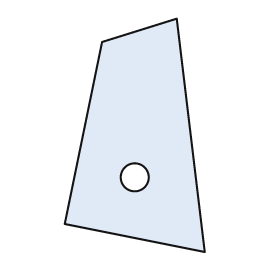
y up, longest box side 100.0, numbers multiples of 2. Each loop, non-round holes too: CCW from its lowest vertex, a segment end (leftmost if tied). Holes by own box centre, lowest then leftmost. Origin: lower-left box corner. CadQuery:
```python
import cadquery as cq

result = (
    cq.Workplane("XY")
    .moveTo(60.0, 0.0)
    .lineTo(48.0, 100.0)
    .lineTo(16.0, 90.0)
    .lineTo(0.0, 12.0)
    .close()
    .moveTo(30.0, 32.0)
    .circle(6.0)
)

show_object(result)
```